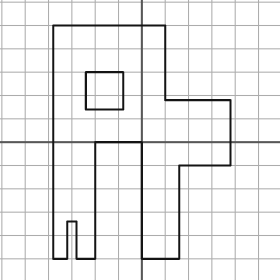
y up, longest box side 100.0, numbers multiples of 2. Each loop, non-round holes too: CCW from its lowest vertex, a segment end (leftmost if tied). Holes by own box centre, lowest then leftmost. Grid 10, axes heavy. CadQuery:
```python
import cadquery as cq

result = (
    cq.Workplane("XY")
    .moveTo(-38.0, -50.0)
    .lineTo(-32.0, -50.0)
    .lineTo(-32.0, -34.0)
    .lineTo(-28.0, -34.0)
    .lineTo(-28.0, -50.0)
    .lineTo(-20.0, -50.0)
    .lineTo(-20.0, 0.0)
    .lineTo(0.0, 0.0)
    .lineTo(0.0, -50.0)
    .lineTo(16.0, -50.0)
    .lineTo(16.0, -10.0)
    .lineTo(38.0, -10.0)
    .lineTo(38.0, 18.0)
    .lineTo(10.0, 18.0)
    .lineTo(10.0, 50.0)
    .lineTo(-38.0, 50.0)
    .close()
    .moveTo(-24.0, 14.0)
    .lineTo(-8.0, 14.0)
    .lineTo(-8.0, 30.0)
    .lineTo(-24.0, 30.0)
    .close()
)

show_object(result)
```